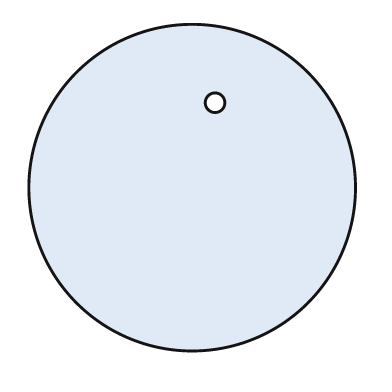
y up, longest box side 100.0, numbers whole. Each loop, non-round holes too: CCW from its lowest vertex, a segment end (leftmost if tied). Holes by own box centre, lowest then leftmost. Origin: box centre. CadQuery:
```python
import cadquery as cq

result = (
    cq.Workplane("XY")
    .moveTo(0.0, 0.0)
    .circle(50.0)
    .moveTo(7.0, 26.0)
    .circle(3.0)
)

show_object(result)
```